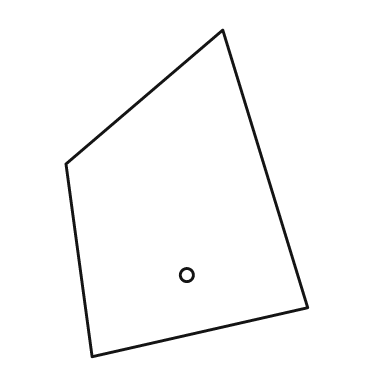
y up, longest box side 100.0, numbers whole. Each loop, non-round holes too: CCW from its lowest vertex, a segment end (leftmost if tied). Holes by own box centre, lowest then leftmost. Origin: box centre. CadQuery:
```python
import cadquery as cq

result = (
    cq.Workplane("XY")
    .moveTo(-29.0, -50.0)
    .lineTo(37.0, -35.0)
    .lineTo(11.0, 50.0)
    .lineTo(-37.0, 9.0)
    .close()
    .moveTo(0.0, -25.0)
    .circle(2.0)
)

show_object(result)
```